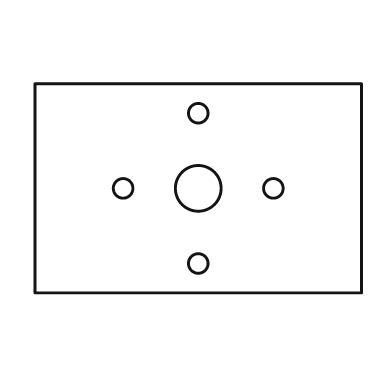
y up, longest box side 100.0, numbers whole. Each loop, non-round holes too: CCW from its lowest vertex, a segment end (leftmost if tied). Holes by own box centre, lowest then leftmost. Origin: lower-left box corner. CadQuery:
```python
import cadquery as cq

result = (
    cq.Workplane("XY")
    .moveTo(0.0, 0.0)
    .lineTo(100.0, 0.0)
    .lineTo(100.0, 64.0)
    .lineTo(0.0, 64.0)
    .close()
    .moveTo(50.0, 9.0)
    .circle(3.0)
    .moveTo(27.0, 32.0)
    .circle(3.0)
    .moveTo(50.0, 32.0)
    .circle(7.0)
    .moveTo(73.0, 32.0)
    .circle(3.0)
    .moveTo(50.0, 55.0)
    .circle(3.0)
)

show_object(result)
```